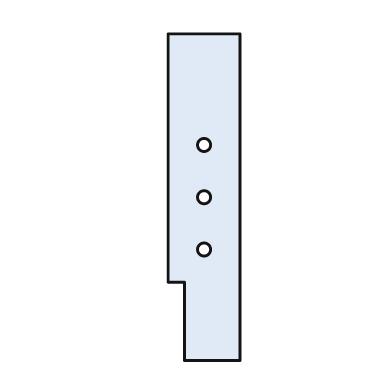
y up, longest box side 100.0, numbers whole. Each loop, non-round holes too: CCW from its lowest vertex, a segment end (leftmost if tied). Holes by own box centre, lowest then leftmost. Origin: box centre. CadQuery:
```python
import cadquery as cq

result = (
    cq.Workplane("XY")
    .moveTo(-6.0, -50.0)
    .lineTo(11.0, -50.0)
    .lineTo(11.0, 50.0)
    .lineTo(-11.0, 50.0)
    .lineTo(-11.0, -26.0)
    .lineTo(-6.0, -26.0)
    .close()
    .moveTo(0.0, -16.0)
    .circle(2.0)
    .moveTo(0.0, 0.0)
    .circle(2.0)
    .moveTo(0.0, 16.0)
    .circle(2.0)
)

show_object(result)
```